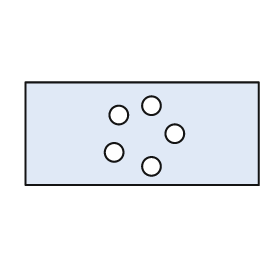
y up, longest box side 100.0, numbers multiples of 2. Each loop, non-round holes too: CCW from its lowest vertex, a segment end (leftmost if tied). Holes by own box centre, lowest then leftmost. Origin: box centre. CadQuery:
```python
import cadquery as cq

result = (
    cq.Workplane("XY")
    .moveTo(-50.0, -22.0)
    .lineTo(50.0, -22.0)
    .lineTo(50.0, 22.0)
    .lineTo(-50.0, 22.0)
    .close()
    .moveTo(4.0, -14.0)
    .circle(4.0)
    .moveTo(-12.0, -8.0)
    .circle(4.0)
    .moveTo(14.0, 0.0)
    .circle(4.0)
    .moveTo(-10.0, 8.0)
    .circle(4.0)
    .moveTo(4.0, 12.0)
    .circle(4.0)
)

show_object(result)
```